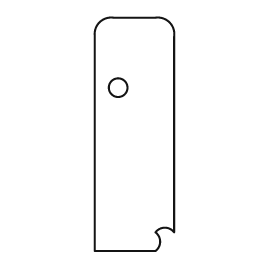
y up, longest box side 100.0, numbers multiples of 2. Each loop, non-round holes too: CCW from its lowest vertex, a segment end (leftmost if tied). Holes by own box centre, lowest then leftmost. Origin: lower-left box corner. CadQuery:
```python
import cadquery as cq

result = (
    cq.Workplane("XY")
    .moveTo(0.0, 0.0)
    .lineTo(26.0, 0.0)
    .threePointArc((28.0, 4.0), (26.0, 8.0))
    .threePointArc((30.0, 10.0), (34.0, 8.0))
    .lineTo(34.0, 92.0)
    .threePointArc((32.0, 98.0), (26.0, 100.0))
    .lineTo(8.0, 100.0)
    .threePointArc((2.0, 98.0), (0.0, 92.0))
    .close()
    .moveTo(10.0, 70.0)
    .circle(4.0)
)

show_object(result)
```